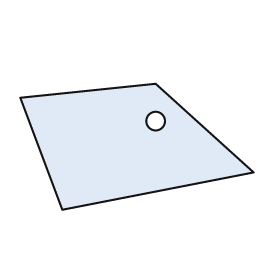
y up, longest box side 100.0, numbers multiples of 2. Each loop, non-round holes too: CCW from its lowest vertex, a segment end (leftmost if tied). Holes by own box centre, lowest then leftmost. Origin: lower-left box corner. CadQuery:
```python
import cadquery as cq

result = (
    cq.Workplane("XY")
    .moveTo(18.0, 0.0)
    .lineTo(100.0, 16.0)
    .lineTo(58.0, 54.0)
    .lineTo(0.0, 48.0)
    .close()
    .moveTo(58.0, 38.0)
    .circle(4.0)
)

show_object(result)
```